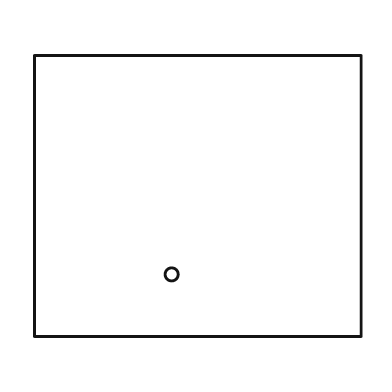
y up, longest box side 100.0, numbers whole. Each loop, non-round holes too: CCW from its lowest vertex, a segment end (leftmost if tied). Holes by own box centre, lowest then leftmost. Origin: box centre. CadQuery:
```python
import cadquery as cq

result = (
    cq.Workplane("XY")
    .moveTo(-50.0, -43.0)
    .lineTo(50.0, -43.0)
    .lineTo(50.0, 43.0)
    .lineTo(-50.0, 43.0)
    .close()
    .moveTo(-8.0, -24.0)
    .circle(2.0)
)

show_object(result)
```